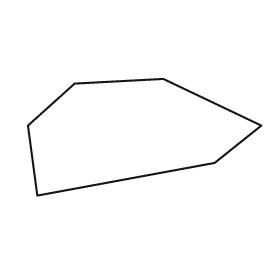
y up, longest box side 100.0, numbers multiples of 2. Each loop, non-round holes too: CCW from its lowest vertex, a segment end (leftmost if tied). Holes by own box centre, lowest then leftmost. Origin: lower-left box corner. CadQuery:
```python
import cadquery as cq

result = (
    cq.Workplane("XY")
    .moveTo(4.0, 0.0)
    .lineTo(80.0, 14.0)
    .lineTo(100.0, 30.0)
    .lineTo(58.0, 50.0)
    .lineTo(20.0, 48.0)
    .lineTo(0.0, 30.0)
    .close()
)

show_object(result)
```